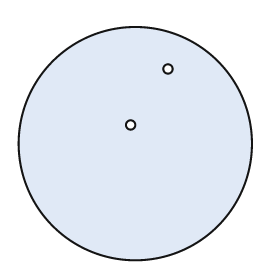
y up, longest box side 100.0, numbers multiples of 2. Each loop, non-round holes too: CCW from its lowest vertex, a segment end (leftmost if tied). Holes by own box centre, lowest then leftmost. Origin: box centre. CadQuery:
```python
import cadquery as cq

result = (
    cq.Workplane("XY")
    .moveTo(0.0, 0.0)
    .circle(50.0)
    .moveTo(-2.0, 8.0)
    .circle(2.0)
    .moveTo(14.0, 32.0)
    .circle(2.0)
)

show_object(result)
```